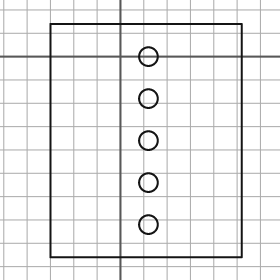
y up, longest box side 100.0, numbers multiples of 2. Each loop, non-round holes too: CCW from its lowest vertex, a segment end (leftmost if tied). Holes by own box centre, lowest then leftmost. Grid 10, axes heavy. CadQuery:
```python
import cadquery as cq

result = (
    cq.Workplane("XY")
    .moveTo(-30.0, -86.0)
    .lineTo(52.0, -86.0)
    .lineTo(52.0, 14.0)
    .lineTo(-30.0, 14.0)
    .close()
    .moveTo(12.0, -72.0)
    .circle(4.0)
    .moveTo(12.0, -54.0)
    .circle(4.0)
    .moveTo(12.0, -36.0)
    .circle(4.0)
    .moveTo(12.0, -18.0)
    .circle(4.0)
    .moveTo(12.0, 0.0)
    .circle(4.0)
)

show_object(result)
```